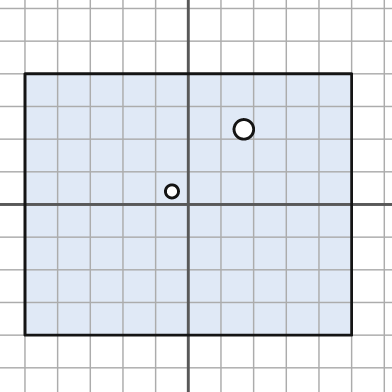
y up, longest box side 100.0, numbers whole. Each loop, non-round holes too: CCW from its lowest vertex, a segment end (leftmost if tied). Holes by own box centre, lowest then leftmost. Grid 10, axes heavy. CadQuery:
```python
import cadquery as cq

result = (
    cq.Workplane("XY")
    .moveTo(-50.0, -40.0)
    .lineTo(50.0, -40.0)
    .lineTo(50.0, 40.0)
    .lineTo(-50.0, 40.0)
    .close()
    .moveTo(-5.0, 4.0)
    .circle(2.0)
    .moveTo(17.0, 23.0)
    .circle(3.0)
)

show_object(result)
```